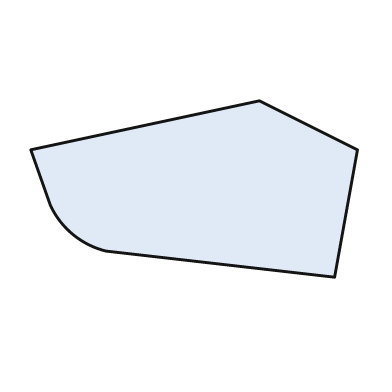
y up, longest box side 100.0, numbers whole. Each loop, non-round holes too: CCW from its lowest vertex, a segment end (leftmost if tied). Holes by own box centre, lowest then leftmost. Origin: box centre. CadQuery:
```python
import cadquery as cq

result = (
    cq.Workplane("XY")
    .moveTo(43.0, -27.0)
    .lineTo(50.0, 12.0)
    .lineTo(20.0, 27.0)
    .lineTo(-50.0, 12.0)
    .lineTo(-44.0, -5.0)
    .threePointArc((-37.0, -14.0), (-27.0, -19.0))
    .close()
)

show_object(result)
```